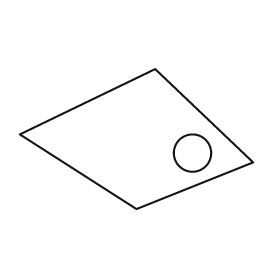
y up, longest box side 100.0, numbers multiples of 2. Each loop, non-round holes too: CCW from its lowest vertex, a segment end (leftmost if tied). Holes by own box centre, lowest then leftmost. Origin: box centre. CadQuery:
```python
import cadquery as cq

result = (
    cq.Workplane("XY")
    .moveTo(0.0, -30.0)
    .lineTo(50.0, -10.0)
    .lineTo(8.0, 30.0)
    .lineTo(-50.0, 2.0)
    .close()
    .moveTo(24.0, -6.0)
    .circle(8.0)
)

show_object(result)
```